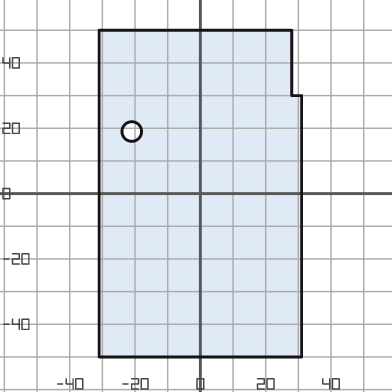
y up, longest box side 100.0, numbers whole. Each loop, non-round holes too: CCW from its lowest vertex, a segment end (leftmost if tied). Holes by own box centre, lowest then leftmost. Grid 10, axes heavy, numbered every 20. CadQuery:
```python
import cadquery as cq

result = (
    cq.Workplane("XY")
    .moveTo(-31.0, -50.0)
    .lineTo(31.0, -50.0)
    .lineTo(31.0, 30.0)
    .lineTo(28.0, 30.0)
    .lineTo(28.0, 50.0)
    .lineTo(-31.0, 50.0)
    .close()
    .moveTo(-21.0, 19.0)
    .circle(3.0)
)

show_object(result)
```